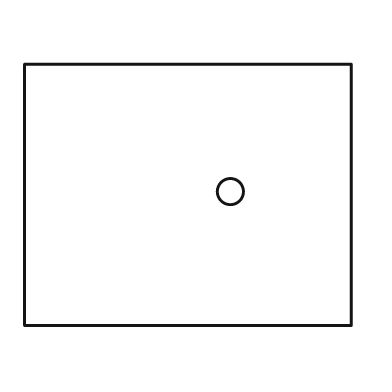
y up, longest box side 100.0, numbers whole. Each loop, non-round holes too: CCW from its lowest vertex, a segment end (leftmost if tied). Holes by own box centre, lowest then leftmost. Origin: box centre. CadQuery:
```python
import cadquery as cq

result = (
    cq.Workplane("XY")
    .moveTo(-50.0, -40.0)
    .lineTo(50.0, -40.0)
    .lineTo(50.0, 40.0)
    .lineTo(-50.0, 40.0)
    .close()
    .moveTo(13.0, 1.0)
    .circle(4.0)
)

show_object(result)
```